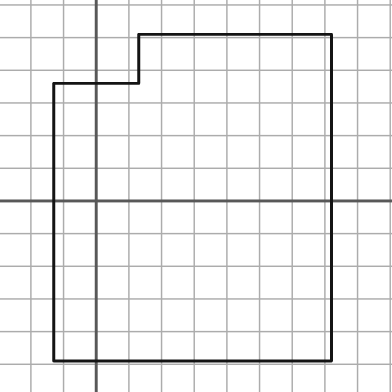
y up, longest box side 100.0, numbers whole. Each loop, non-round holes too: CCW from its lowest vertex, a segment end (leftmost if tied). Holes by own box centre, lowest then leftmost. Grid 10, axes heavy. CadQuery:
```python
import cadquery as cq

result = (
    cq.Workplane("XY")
    .moveTo(-13.0, -49.0)
    .lineTo(72.0, -49.0)
    .lineTo(72.0, 51.0)
    .lineTo(13.0, 51.0)
    .lineTo(13.0, 36.0)
    .lineTo(-13.0, 36.0)
    .close()
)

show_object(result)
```